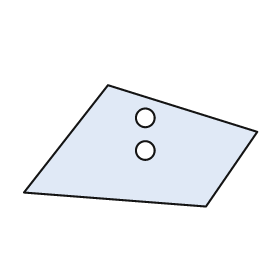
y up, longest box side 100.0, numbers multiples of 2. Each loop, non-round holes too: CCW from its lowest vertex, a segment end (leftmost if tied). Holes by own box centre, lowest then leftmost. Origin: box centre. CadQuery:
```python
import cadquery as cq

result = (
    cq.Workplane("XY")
    .moveTo(28.0, -26.0)
    .lineTo(50.0, 6.0)
    .lineTo(-14.0, 26.0)
    .lineTo(-50.0, -20.0)
    .close()
    .moveTo(2.0, -2.0)
    .circle(4.0)
    .moveTo(2.0, 12.0)
    .circle(4.0)
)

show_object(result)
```